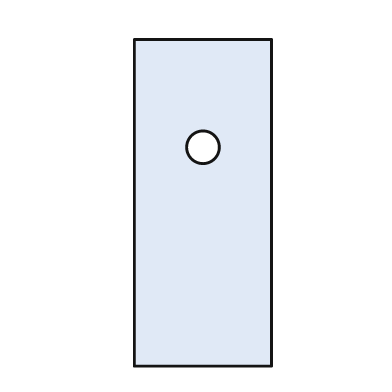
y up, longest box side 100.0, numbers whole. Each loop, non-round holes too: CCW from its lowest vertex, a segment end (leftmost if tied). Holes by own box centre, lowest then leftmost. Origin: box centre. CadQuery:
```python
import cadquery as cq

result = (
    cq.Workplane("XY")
    .moveTo(-21.0, -50.0)
    .lineTo(21.0, -50.0)
    .lineTo(21.0, 50.0)
    .lineTo(-21.0, 50.0)
    .close()
    .moveTo(0.0, 17.0)
    .circle(5.0)
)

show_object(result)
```